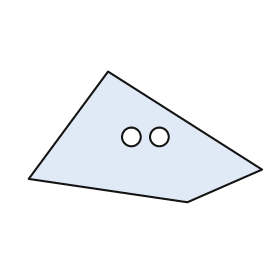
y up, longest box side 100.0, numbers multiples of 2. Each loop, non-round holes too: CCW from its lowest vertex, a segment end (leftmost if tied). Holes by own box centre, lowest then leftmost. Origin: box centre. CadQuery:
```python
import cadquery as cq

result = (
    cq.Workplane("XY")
    .moveTo(18.0, -28.0)
    .lineTo(50.0, -14.0)
    .lineTo(-16.0, 28.0)
    .lineTo(-50.0, -18.0)
    .close()
    .moveTo(-6.0, 0.0)
    .circle(4.0)
    .moveTo(6.0, 0.0)
    .circle(4.0)
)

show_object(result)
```